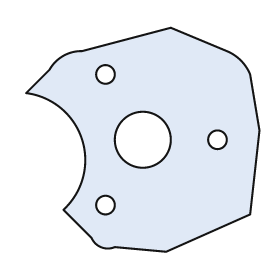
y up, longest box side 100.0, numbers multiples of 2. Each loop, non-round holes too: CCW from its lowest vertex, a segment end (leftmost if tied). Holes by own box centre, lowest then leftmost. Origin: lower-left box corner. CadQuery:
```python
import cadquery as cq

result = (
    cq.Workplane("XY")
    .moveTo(60.0, 0.0)
    .lineTo(96.0, 16.0)
    .lineTo(100.0, 52.0)
    .lineTo(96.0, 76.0)
    .threePointArc((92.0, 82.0), (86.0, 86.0))
    .lineTo(62.0, 96.0)
    .lineTo(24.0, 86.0)
    .threePointArc((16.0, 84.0), (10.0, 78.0))
    .lineTo(0.0, 68.0)
    .threePointArc((24.0, 48.0), (16.0, 18.0))
    .lineTo(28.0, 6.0)
    .threePointArc((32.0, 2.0), (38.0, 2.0))
    .close()
    .moveTo(34.0, 20.0)
    .circle(4.0)
    .moveTo(50.0, 48.0)
    .circle(12.0)
    .moveTo(82.0, 48.0)
    .circle(4.0)
    .moveTo(34.0, 76.0)
    .circle(4.0)
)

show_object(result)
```